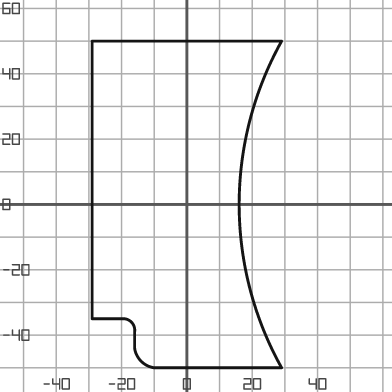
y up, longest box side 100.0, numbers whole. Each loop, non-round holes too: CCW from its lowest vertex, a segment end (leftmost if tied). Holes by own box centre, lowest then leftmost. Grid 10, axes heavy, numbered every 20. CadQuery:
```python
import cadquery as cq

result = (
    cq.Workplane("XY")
    .moveTo(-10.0, -50.0)
    .lineTo(29.0, -50.0)
    .threePointArc((16.0, 0.0), (29.0, 50.0))
    .lineTo(-29.0, 50.0)
    .lineTo(-29.0, -35.0)
    .lineTo(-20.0, -35.0)
    .threePointArc((-17.0, -36.0), (-16.0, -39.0))
    .lineTo(-16.0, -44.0)
    .threePointArc((-14.0, -48.0), (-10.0, -50.0))
    .close()
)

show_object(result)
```